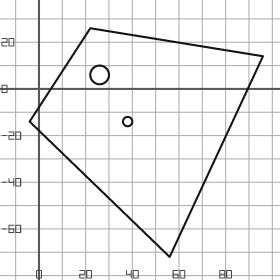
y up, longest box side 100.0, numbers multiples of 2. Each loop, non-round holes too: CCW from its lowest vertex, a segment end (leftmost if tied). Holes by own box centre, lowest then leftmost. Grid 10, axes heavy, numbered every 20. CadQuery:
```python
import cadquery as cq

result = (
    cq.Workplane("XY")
    .moveTo(56.0, -72.0)
    .lineTo(96.0, 14.0)
    .lineTo(22.0, 26.0)
    .lineTo(-4.0, -14.0)
    .close()
    .moveTo(38.0, -14.0)
    .circle(2.0)
    .moveTo(26.0, 6.0)
    .circle(4.0)
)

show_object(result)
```